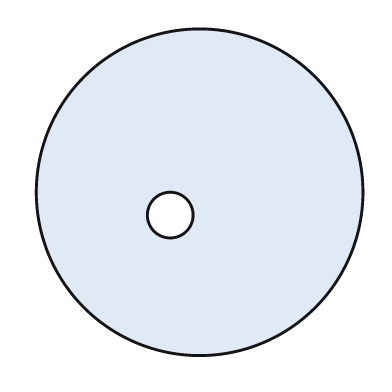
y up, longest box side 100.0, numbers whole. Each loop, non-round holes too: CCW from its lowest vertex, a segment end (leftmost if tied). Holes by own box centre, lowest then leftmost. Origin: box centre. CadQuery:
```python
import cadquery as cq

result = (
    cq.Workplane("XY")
    .moveTo(0.0, 0.0)
    .circle(50.0)
    .moveTo(-9.0, -7.0)
    .circle(7.0)
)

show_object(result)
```